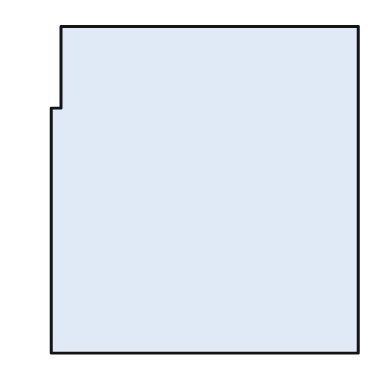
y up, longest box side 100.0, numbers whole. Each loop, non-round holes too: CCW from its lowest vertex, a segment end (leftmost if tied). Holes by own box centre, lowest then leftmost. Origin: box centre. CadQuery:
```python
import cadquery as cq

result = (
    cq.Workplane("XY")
    .moveTo(-47.0, -50.0)
    .lineTo(47.0, -50.0)
    .lineTo(47.0, 50.0)
    .lineTo(-44.0, 50.0)
    .lineTo(-44.0, 25.0)
    .lineTo(-47.0, 25.0)
    .close()
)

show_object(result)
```